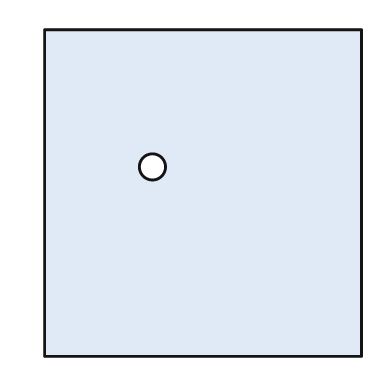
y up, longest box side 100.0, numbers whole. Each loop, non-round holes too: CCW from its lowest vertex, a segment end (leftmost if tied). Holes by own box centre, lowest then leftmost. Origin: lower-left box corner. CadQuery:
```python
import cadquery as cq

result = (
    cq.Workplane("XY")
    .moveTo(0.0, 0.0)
    .lineTo(97.0, 0.0)
    .lineTo(97.0, 100.0)
    .lineTo(0.0, 100.0)
    .close()
    .moveTo(33.0, 58.0)
    .circle(4.0)
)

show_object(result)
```